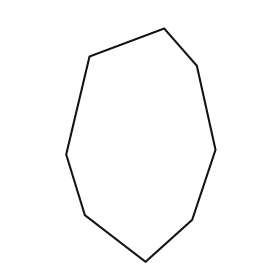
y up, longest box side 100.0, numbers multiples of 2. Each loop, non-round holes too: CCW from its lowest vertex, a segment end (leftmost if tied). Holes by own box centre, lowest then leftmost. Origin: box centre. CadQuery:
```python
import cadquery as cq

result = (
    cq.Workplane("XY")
    .moveTo(2.0, -50.0)
    .lineTo(22.0, -32.0)
    .lineTo(32.0, -2.0)
    .lineTo(24.0, 34.0)
    .lineTo(10.0, 50.0)
    .lineTo(-22.0, 38.0)
    .lineTo(-32.0, -4.0)
    .lineTo(-24.0, -30.0)
    .close()
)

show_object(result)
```